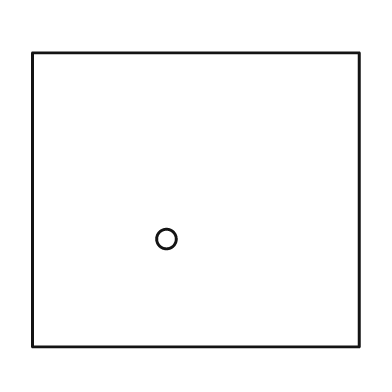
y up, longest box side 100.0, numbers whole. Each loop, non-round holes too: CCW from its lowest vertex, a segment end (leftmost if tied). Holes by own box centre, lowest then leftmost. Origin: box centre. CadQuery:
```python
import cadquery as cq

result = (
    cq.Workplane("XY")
    .moveTo(-50.0, -45.0)
    .lineTo(50.0, -45.0)
    .lineTo(50.0, 45.0)
    .lineTo(-50.0, 45.0)
    .close()
    .moveTo(-9.0, -12.0)
    .circle(3.0)
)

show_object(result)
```